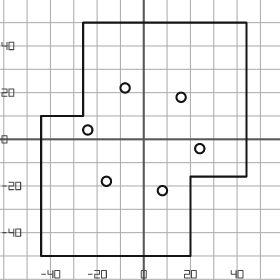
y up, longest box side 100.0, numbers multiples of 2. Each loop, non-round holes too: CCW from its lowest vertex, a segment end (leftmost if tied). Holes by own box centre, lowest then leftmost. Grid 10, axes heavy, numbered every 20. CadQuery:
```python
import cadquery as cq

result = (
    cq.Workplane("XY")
    .moveTo(-44.0, -50.0)
    .lineTo(20.0, -50.0)
    .lineTo(20.0, -16.0)
    .lineTo(44.0, -16.0)
    .lineTo(44.0, 50.0)
    .lineTo(-26.0, 50.0)
    .lineTo(-26.0, 10.0)
    .lineTo(-44.0, 10.0)
    .close()
    .moveTo(8.0, -22.0)
    .circle(2.0)
    .moveTo(-16.0, -18.0)
    .circle(2.0)
    .moveTo(24.0, -4.0)
    .circle(2.0)
    .moveTo(-24.0, 4.0)
    .circle(2.0)
    .moveTo(16.0, 18.0)
    .circle(2.0)
    .moveTo(-8.0, 22.0)
    .circle(2.0)
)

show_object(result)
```